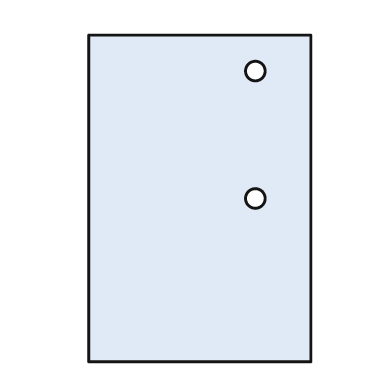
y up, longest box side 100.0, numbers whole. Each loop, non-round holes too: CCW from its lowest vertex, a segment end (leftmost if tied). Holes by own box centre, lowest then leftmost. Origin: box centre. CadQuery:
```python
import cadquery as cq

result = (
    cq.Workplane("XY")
    .moveTo(-34.0, -50.0)
    .lineTo(34.0, -50.0)
    .lineTo(34.0, 50.0)
    .lineTo(-34.0, 50.0)
    .close()
    .moveTo(17.0, 0.0)
    .circle(3.0)
    .moveTo(17.0, 39.0)
    .circle(3.0)
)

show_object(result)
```